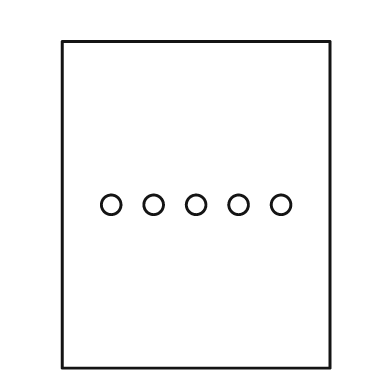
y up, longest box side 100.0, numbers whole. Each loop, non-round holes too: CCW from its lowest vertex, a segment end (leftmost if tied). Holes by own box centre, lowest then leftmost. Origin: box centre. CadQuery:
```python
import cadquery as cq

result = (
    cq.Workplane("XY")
    .moveTo(-41.0, -50.0)
    .lineTo(41.0, -50.0)
    .lineTo(41.0, 50.0)
    .lineTo(-41.0, 50.0)
    .close()
    .moveTo(-26.0, 0.0)
    .circle(3.0)
    .moveTo(-13.0, 0.0)
    .circle(3.0)
    .moveTo(0.0, 0.0)
    .circle(3.0)
    .moveTo(13.0, 0.0)
    .circle(3.0)
    .moveTo(26.0, 0.0)
    .circle(3.0)
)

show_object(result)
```